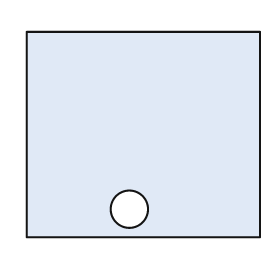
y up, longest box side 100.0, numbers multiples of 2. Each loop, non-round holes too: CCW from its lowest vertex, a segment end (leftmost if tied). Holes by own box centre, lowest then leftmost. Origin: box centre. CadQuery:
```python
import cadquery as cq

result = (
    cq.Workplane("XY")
    .moveTo(-50.0, -44.0)
    .lineTo(50.0, -44.0)
    .lineTo(50.0, 44.0)
    .lineTo(-50.0, 44.0)
    .close()
    .moveTo(-6.0, -32.0)
    .circle(8.0)
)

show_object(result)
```